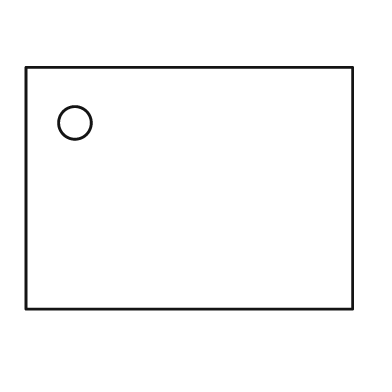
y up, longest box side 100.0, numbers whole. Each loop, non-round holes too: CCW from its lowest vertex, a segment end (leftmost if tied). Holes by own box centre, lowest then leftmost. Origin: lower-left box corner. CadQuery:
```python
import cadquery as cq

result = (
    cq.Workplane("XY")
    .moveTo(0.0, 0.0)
    .lineTo(100.0, 0.0)
    .lineTo(100.0, 74.0)
    .lineTo(0.0, 74.0)
    .close()
    .moveTo(15.0, 57.0)
    .circle(5.0)
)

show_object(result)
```